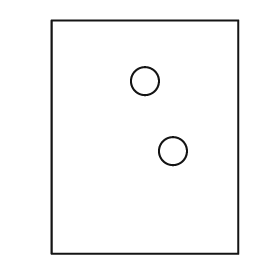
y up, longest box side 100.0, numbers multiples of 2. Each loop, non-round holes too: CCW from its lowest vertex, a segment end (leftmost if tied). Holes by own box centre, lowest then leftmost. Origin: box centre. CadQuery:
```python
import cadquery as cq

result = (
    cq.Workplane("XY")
    .moveTo(-40.0, -50.0)
    .lineTo(40.0, -50.0)
    .lineTo(40.0, 50.0)
    .lineTo(-40.0, 50.0)
    .close()
    .moveTo(12.0, -6.0)
    .circle(6.0)
    .moveTo(0.0, 24.0)
    .circle(6.0)
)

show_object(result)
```